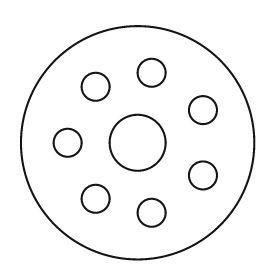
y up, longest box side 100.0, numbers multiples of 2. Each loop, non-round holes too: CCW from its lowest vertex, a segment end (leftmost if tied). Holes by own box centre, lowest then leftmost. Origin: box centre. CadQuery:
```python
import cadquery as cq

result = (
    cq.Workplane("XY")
    .moveTo(0.0, 0.0)
    .circle(50.0)
    .moveTo(6.0, -30.0)
    .circle(6.0)
    .moveTo(-18.0, -24.0)
    .circle(6.0)
    .moveTo(28.0, -14.0)
    .circle(6.0)
    .moveTo(-30.0, 0.0)
    .circle(6.0)
    .moveTo(0.0, 0.0)
    .circle(12.0)
    .moveTo(28.0, 14.0)
    .circle(6.0)
    .moveTo(-18.0, 24.0)
    .circle(6.0)
    .moveTo(6.0, 30.0)
    .circle(6.0)
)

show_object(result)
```